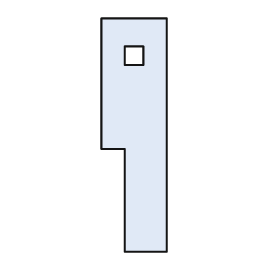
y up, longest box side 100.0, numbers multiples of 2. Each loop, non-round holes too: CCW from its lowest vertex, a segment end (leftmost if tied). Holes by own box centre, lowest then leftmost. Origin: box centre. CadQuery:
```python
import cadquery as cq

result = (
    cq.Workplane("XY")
    .moveTo(-4.0, -50.0)
    .lineTo(14.0, -50.0)
    .lineTo(14.0, 50.0)
    .lineTo(-14.0, 50.0)
    .lineTo(-14.0, -6.0)
    .lineTo(-4.0, -6.0)
    .close()
    .moveTo(-4.0, 30.0)
    .lineTo(4.0, 30.0)
    .lineTo(4.0, 38.0)
    .lineTo(-4.0, 38.0)
    .close()
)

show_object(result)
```